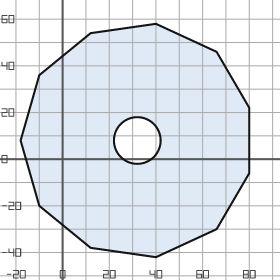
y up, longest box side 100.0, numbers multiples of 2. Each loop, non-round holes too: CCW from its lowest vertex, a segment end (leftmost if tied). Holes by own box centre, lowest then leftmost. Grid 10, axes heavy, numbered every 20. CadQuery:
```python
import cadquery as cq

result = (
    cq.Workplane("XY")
    .moveTo(40.0, -42.0)
    .lineTo(66.0, -30.0)
    .lineTo(80.0, -6.0)
    .lineTo(80.0, 22.0)
    .lineTo(66.0, 46.0)
    .lineTo(40.0, 58.0)
    .lineTo(12.0, 54.0)
    .lineTo(-10.0, 36.0)
    .lineTo(-18.0, 8.0)
    .lineTo(-10.0, -20.0)
    .lineTo(12.0, -38.0)
    .close()
    .moveTo(32.0, 8.0)
    .circle(10.0)
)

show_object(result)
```